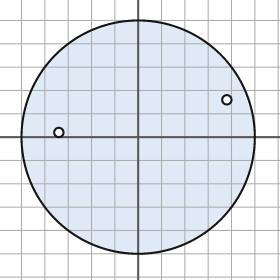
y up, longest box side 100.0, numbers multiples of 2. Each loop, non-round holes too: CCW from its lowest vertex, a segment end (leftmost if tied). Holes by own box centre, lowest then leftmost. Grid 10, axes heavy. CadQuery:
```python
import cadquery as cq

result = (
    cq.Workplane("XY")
    .moveTo(0.0, 0.0)
    .circle(50.0)
    .moveTo(-34.0, 2.0)
    .circle(2.0)
    .moveTo(38.0, 16.0)
    .circle(2.0)
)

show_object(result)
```